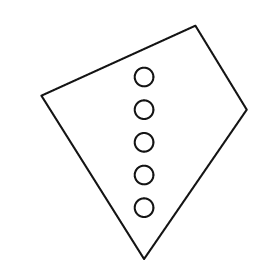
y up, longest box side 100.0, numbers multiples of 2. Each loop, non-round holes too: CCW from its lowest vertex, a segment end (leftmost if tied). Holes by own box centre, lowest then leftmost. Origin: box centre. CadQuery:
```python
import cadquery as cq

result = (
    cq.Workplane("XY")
    .moveTo(0.0, -50.0)
    .lineTo(44.0, 14.0)
    .lineTo(22.0, 50.0)
    .lineTo(-44.0, 20.0)
    .close()
    .moveTo(0.0, -28.0)
    .circle(4.0)
    .moveTo(0.0, -14.0)
    .circle(4.0)
    .moveTo(0.0, 0.0)
    .circle(4.0)
    .moveTo(0.0, 14.0)
    .circle(4.0)
    .moveTo(0.0, 28.0)
    .circle(4.0)
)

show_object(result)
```